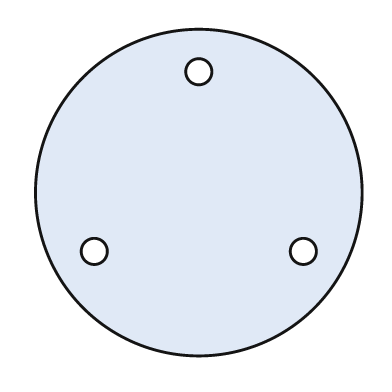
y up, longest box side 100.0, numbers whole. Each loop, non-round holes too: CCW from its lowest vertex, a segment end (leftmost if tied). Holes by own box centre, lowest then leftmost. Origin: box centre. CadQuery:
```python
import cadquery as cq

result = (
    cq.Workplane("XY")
    .moveTo(0.0, 0.0)
    .circle(50.0)
    .moveTo(-32.0, -18.0)
    .circle(4.0)
    .moveTo(32.0, -18.0)
    .circle(4.0)
    .moveTo(0.0, 37.0)
    .circle(4.0)
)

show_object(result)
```